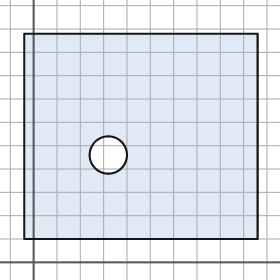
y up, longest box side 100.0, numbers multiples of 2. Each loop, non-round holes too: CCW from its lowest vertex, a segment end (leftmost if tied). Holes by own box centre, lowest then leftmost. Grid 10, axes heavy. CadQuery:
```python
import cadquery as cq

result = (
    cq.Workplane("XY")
    .moveTo(-4.0, 10.0)
    .lineTo(96.0, 10.0)
    .lineTo(96.0, 98.0)
    .lineTo(-4.0, 98.0)
    .close()
    .moveTo(32.0, 46.0)
    .circle(8.0)
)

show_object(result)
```